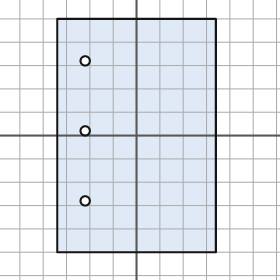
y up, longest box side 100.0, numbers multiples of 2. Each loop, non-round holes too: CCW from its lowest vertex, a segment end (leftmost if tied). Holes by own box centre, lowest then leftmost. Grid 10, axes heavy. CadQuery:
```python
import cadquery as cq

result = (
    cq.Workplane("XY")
    .moveTo(-34.0, -50.0)
    .lineTo(34.0, -50.0)
    .lineTo(34.0, 50.0)
    .lineTo(-34.0, 50.0)
    .close()
    .moveTo(-22.0, -28.0)
    .circle(2.0)
    .moveTo(-22.0, 2.0)
    .circle(2.0)
    .moveTo(-22.0, 32.0)
    .circle(2.0)
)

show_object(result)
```